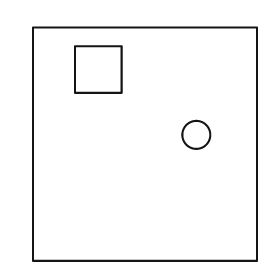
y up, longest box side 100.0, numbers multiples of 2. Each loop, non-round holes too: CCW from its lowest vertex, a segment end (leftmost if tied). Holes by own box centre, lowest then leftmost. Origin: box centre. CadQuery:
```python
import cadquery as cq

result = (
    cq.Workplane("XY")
    .moveTo(-48.0, -50.0)
    .lineTo(48.0, -50.0)
    .lineTo(48.0, 50.0)
    .lineTo(-48.0, 50.0)
    .close()
    .moveTo(22.0, 4.0)
    .circle(6.0)
    .moveTo(-30.0, 22.0)
    .lineTo(-10.0, 22.0)
    .lineTo(-10.0, 42.0)
    .lineTo(-30.0, 42.0)
    .close()
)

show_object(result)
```